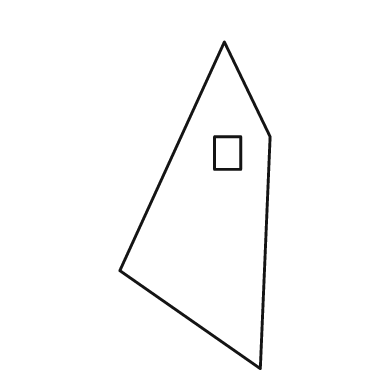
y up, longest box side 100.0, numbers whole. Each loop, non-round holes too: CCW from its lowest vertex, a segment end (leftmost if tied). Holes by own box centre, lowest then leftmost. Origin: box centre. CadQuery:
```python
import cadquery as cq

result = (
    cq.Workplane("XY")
    .moveTo(20.0, -50.0)
    .lineTo(23.0, 21.0)
    .lineTo(9.0, 50.0)
    .lineTo(-23.0, -20.0)
    .close()
    .moveTo(6.0, 11.0)
    .lineTo(14.0, 11.0)
    .lineTo(14.0, 21.0)
    .lineTo(6.0, 21.0)
    .close()
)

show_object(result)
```